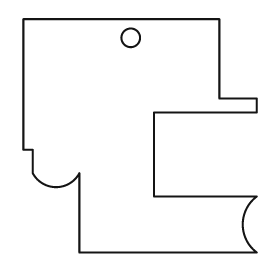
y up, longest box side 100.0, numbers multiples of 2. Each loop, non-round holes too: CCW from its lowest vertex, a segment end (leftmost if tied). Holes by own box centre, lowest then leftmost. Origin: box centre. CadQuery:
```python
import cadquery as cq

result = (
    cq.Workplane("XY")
    .moveTo(-26.0, -50.0)
    .lineTo(50.0, -50.0)
    .threePointArc((44.0, -38.0), (50.0, -26.0))
    .lineTo(6.0, -26.0)
    .lineTo(6.0, 10.0)
    .lineTo(50.0, 10.0)
    .lineTo(50.0, 16.0)
    .lineTo(34.0, 16.0)
    .lineTo(34.0, 50.0)
    .lineTo(-50.0, 50.0)
    .lineTo(-50.0, -6.0)
    .lineTo(-46.0, -6.0)
    .lineTo(-46.0, -16.0)
    .threePointArc((-36.0, -22.0), (-26.0, -16.0))
    .close()
    .moveTo(-4.0, 42.0)
    .circle(4.0)
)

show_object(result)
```